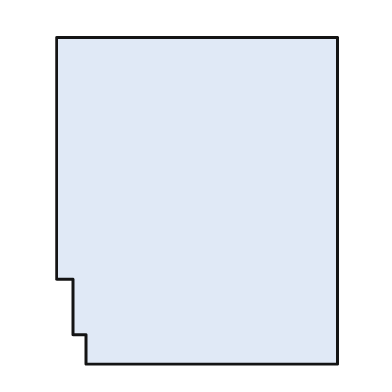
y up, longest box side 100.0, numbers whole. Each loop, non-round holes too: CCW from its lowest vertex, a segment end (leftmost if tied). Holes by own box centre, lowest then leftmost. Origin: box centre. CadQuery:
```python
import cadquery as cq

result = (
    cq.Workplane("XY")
    .moveTo(-34.0, -50.0)
    .lineTo(43.0, -50.0)
    .lineTo(43.0, 50.0)
    .lineTo(-43.0, 50.0)
    .lineTo(-43.0, -24.0)
    .lineTo(-38.0, -24.0)
    .lineTo(-38.0, -41.0)
    .lineTo(-34.0, -41.0)
    .close()
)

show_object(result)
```